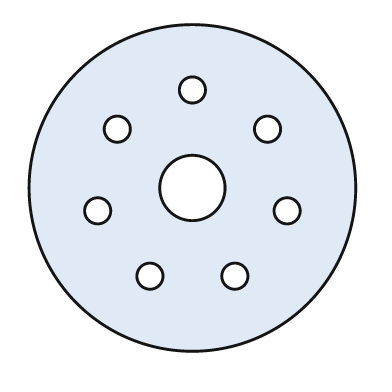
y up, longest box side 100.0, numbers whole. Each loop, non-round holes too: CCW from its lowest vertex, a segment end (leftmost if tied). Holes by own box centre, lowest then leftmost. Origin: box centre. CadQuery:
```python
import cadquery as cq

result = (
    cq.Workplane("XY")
    .moveTo(0.0, 0.0)
    .circle(50.0)
    .moveTo(-13.0, -27.0)
    .circle(4.0)
    .moveTo(13.0, -27.0)
    .circle(4.0)
    .moveTo(-29.0, -7.0)
    .circle(4.0)
    .moveTo(29.0, -7.0)
    .circle(4.0)
    .moveTo(0.0, 0.0)
    .circle(10.0)
    .moveTo(-23.0, 18.0)
    .circle(4.0)
    .moveTo(23.0, 18.0)
    .circle(4.0)
    .moveTo(0.0, 30.0)
    .circle(4.0)
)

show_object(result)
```